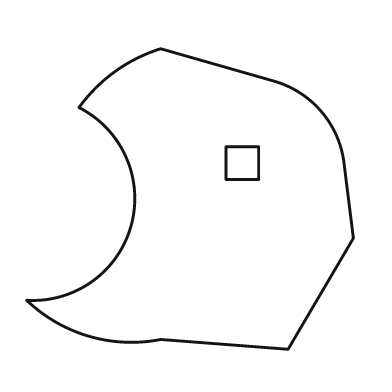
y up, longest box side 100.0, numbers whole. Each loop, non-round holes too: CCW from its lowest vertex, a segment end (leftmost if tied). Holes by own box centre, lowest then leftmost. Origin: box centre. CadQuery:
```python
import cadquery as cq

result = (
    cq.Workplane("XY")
    .moveTo(30.0, -46.0)
    .lineTo(50.0, -12.0)
    .lineTo(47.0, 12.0)
    .threePointArc((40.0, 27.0), (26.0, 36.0))
    .lineTo(-9.0, 46.0)
    .threePointArc((-23.0, 39.0), (-34.0, 28.0))
    .threePointArc((-18.0, -8.0), (-50.0, -31.0))
    .threePointArc((-31.0, -42.0), (-9.0, -43.0))
    .close()
    .moveTo(11.0, 6.0)
    .lineTo(21.0, 6.0)
    .lineTo(21.0, 16.0)
    .lineTo(11.0, 16.0)
    .close()
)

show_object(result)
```